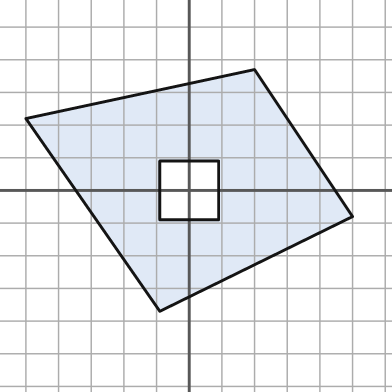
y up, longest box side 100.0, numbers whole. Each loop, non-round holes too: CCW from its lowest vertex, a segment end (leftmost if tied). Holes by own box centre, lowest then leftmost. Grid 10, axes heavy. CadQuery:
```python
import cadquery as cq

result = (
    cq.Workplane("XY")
    .moveTo(-9.0, -37.0)
    .lineTo(50.0, -8.0)
    .lineTo(20.0, 37.0)
    .lineTo(-50.0, 22.0)
    .close()
    .moveTo(-9.0, -9.0)
    .lineTo(9.0, -9.0)
    .lineTo(9.0, 9.0)
    .lineTo(-9.0, 9.0)
    .close()
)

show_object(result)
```